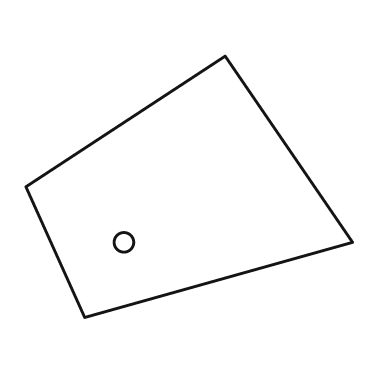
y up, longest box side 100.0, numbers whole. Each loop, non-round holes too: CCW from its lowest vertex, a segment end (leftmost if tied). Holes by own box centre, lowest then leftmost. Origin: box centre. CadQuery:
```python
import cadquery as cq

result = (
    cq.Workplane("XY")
    .moveTo(-32.0, -40.0)
    .lineTo(50.0, -17.0)
    .lineTo(11.0, 40.0)
    .lineTo(-50.0, 0.0)
    .close()
    .moveTo(-20.0, -17.0)
    .circle(3.0)
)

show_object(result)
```